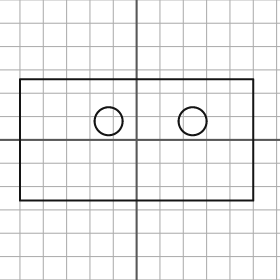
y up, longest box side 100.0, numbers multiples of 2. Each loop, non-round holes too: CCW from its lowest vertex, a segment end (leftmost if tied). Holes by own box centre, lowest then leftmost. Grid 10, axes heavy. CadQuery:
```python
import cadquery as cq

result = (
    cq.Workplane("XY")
    .moveTo(-50.0, -26.0)
    .lineTo(50.0, -26.0)
    .lineTo(50.0, 26.0)
    .lineTo(-50.0, 26.0)
    .close()
    .moveTo(-12.0, 8.0)
    .circle(6.0)
    .moveTo(24.0, 8.0)
    .circle(6.0)
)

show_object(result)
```